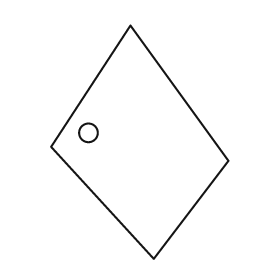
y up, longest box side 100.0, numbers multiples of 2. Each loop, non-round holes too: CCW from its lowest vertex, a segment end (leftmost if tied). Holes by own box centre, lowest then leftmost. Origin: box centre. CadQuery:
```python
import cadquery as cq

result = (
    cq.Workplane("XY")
    .moveTo(6.0, -50.0)
    .lineTo(38.0, -8.0)
    .lineTo(-4.0, 50.0)
    .lineTo(-38.0, -2.0)
    .close()
    .moveTo(-22.0, 4.0)
    .circle(4.0)
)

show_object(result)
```